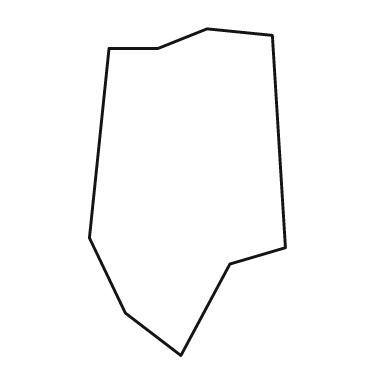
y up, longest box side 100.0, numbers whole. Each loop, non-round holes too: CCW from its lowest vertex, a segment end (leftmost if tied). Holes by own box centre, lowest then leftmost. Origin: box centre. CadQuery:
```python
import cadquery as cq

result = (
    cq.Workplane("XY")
    .moveTo(-2.0, -50.0)
    .lineTo(13.0, -22.0)
    .lineTo(30.0, -17.0)
    .lineTo(26.0, 48.0)
    .lineTo(6.0, 50.0)
    .lineTo(-9.0, 44.0)
    .lineTo(-24.0, 44.0)
    .lineTo(-30.0, -14.0)
    .lineTo(-19.0, -37.0)
    .close()
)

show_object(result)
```